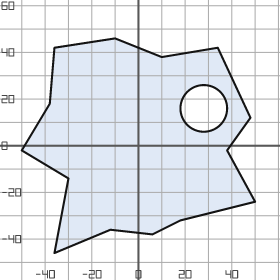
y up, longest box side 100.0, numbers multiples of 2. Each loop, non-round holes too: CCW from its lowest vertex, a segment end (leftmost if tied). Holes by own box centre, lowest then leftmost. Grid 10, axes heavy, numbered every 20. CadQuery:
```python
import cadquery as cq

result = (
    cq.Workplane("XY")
    .moveTo(-36.0, -46.0)
    .lineTo(-12.0, -36.0)
    .lineTo(6.0, -38.0)
    .lineTo(18.0, -32.0)
    .lineTo(50.0, -24.0)
    .lineTo(38.0, -2.0)
    .lineTo(48.0, 12.0)
    .lineTo(34.0, 42.0)
    .lineTo(10.0, 38.0)
    .lineTo(-10.0, 46.0)
    .lineTo(-36.0, 42.0)
    .lineTo(-38.0, 18.0)
    .lineTo(-50.0, -2.0)
    .lineTo(-30.0, -14.0)
    .close()
    .moveTo(28.0, 16.0)
    .circle(10.0)
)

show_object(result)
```